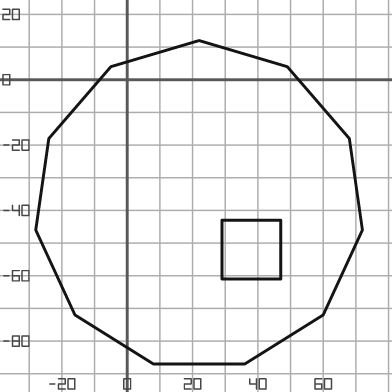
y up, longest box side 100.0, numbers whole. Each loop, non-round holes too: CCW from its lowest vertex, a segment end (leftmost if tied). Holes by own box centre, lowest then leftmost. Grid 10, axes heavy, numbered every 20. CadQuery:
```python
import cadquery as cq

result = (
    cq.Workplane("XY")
    .moveTo(8.0, -87.0)
    .lineTo(36.0, -87.0)
    .lineTo(60.0, -72.0)
    .lineTo(72.0, -46.0)
    .lineTo(68.0, -18.0)
    .lineTo(49.0, 4.0)
    .lineTo(22.0, 12.0)
    .lineTo(-5.0, 4.0)
    .lineTo(-24.0, -18.0)
    .lineTo(-28.0, -46.0)
    .lineTo(-16.0, -72.0)
    .close()
    .moveTo(29.0, -61.0)
    .lineTo(47.0, -61.0)
    .lineTo(47.0, -43.0)
    .lineTo(29.0, -43.0)
    .close()
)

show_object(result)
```